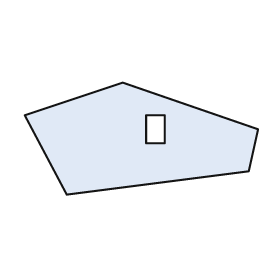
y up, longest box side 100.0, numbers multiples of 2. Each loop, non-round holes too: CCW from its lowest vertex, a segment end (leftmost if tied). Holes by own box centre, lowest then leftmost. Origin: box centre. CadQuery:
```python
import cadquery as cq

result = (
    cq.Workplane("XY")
    .moveTo(-32.0, -24.0)
    .lineTo(46.0, -14.0)
    .lineTo(50.0, 4.0)
    .lineTo(-8.0, 24.0)
    .lineTo(-50.0, 10.0)
    .close()
    .moveTo(2.0, -2.0)
    .lineTo(10.0, -2.0)
    .lineTo(10.0, 10.0)
    .lineTo(2.0, 10.0)
    .close()
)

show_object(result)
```